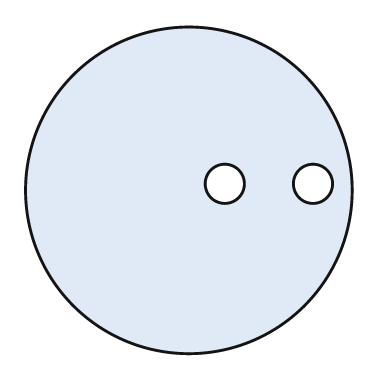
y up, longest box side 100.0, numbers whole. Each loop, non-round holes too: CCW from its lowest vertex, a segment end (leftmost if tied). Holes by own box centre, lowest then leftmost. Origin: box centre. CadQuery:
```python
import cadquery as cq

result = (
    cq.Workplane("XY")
    .moveTo(0.0, 0.0)
    .circle(50.0)
    .moveTo(11.0, 2.0)
    .circle(6.0)
    .moveTo(38.0, 2.0)
    .circle(6.0)
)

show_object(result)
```